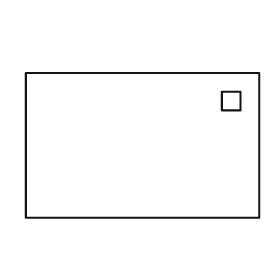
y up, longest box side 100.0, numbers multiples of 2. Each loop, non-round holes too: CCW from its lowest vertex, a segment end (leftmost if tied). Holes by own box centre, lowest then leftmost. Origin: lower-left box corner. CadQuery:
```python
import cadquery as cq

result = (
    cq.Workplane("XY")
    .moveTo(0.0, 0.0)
    .lineTo(100.0, 0.0)
    .lineTo(100.0, 62.0)
    .lineTo(0.0, 62.0)
    .close()
    .moveTo(84.0, 46.0)
    .lineTo(92.0, 46.0)
    .lineTo(92.0, 54.0)
    .lineTo(84.0, 54.0)
    .close()
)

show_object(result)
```